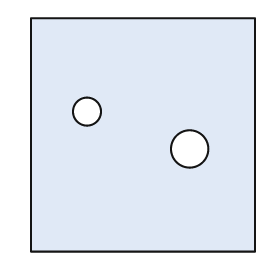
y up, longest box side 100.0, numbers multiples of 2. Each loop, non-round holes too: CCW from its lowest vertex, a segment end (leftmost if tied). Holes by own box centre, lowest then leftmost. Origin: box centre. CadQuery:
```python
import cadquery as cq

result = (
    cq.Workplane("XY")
    .moveTo(-48.0, -50.0)
    .lineTo(48.0, -50.0)
    .lineTo(48.0, 50.0)
    .lineTo(-48.0, 50.0)
    .close()
    .moveTo(20.0, -6.0)
    .circle(8.0)
    .moveTo(-24.0, 10.0)
    .circle(6.0)
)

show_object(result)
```